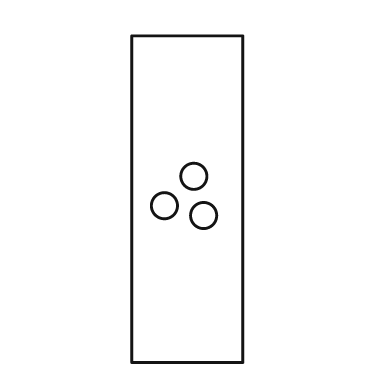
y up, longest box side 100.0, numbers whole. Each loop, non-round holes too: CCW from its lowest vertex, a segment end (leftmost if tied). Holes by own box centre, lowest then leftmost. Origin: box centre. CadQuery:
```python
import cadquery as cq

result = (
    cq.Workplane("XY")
    .moveTo(-17.0, -50.0)
    .lineTo(17.0, -50.0)
    .lineTo(17.0, 50.0)
    .lineTo(-17.0, 50.0)
    .close()
    .moveTo(5.0, -5.0)
    .circle(4.0)
    .moveTo(-7.0, -2.0)
    .circle(4.0)
    .moveTo(2.0, 7.0)
    .circle(4.0)
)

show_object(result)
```